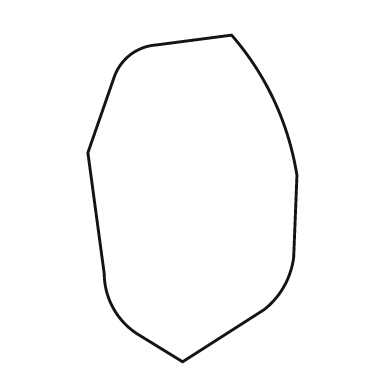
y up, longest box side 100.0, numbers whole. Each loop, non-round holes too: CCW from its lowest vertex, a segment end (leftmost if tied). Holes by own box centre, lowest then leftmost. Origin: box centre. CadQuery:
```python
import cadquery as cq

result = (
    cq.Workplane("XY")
    .moveTo(-3.0, -50.0)
    .lineTo(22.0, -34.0)
    .threePointArc((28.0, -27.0), (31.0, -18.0))
    .lineTo(32.0, 7.0)
    .threePointArc((25.0, 30.0), (12.0, 50.0))
    .lineTo(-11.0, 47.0)
    .threePointArc((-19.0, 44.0), (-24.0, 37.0))
    .lineTo(-32.0, 14.0)
    .lineTo(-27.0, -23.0)
    .threePointArc((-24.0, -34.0), (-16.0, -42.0))
    .close()
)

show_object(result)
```